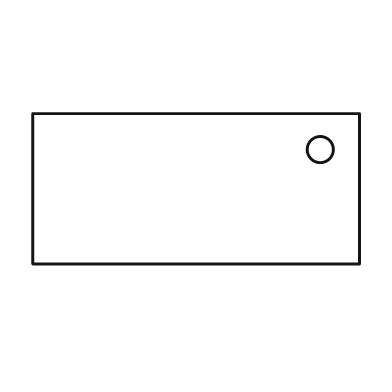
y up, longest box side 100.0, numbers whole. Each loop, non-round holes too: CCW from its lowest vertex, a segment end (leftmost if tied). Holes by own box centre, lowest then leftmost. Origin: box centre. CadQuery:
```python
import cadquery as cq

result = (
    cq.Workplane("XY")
    .moveTo(-50.0, -23.0)
    .lineTo(50.0, -23.0)
    .lineTo(50.0, 23.0)
    .lineTo(-50.0, 23.0)
    .close()
    .moveTo(38.0, 12.0)
    .circle(4.0)
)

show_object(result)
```